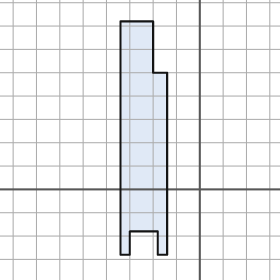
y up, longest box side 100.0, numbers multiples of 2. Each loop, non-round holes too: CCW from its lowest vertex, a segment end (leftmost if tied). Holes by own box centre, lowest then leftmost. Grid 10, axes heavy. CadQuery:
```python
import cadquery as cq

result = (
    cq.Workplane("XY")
    .moveTo(-34.0, -28.0)
    .lineTo(-30.0, -28.0)
    .lineTo(-30.0, -18.0)
    .lineTo(-18.0, -18.0)
    .lineTo(-18.0, -28.0)
    .lineTo(-14.0, -28.0)
    .lineTo(-14.0, 50.0)
    .lineTo(-20.0, 50.0)
    .lineTo(-20.0, 72.0)
    .lineTo(-34.0, 72.0)
    .close()
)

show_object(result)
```